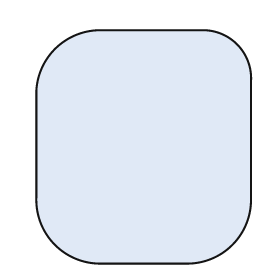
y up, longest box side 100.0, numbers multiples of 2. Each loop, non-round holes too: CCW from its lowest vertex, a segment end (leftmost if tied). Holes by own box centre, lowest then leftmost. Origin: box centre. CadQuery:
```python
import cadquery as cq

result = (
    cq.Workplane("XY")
    .moveTo(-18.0, -50.0)
    .lineTo(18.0, -50.0)
    .threePointArc((38.0, -42.0), (46.0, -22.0))
    .lineTo(46.0, 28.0)
    .threePointArc((40.0, 44.0), (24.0, 50.0))
    .lineTo(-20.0, 50.0)
    .threePointArc((-38.0, 42.0), (-46.0, 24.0))
    .lineTo(-46.0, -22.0)
    .threePointArc((-38.0, -42.0), (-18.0, -50.0))
    .close()
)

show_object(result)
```